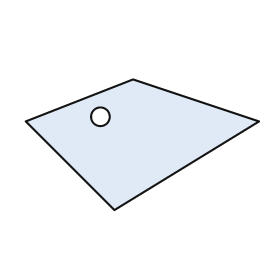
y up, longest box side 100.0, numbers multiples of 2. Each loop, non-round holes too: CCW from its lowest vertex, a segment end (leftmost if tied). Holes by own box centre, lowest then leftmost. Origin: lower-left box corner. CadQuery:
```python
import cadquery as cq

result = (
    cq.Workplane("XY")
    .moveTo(38.0, 0.0)
    .lineTo(100.0, 38.0)
    .lineTo(46.0, 56.0)
    .lineTo(0.0, 38.0)
    .close()
    .moveTo(32.0, 40.0)
    .circle(4.0)
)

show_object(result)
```